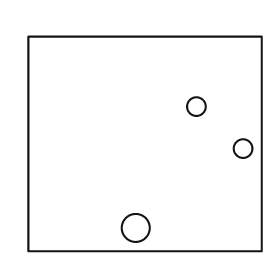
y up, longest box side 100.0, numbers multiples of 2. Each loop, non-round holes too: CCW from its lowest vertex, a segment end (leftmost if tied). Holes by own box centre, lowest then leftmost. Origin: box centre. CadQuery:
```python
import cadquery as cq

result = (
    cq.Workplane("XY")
    .moveTo(-50.0, -46.0)
    .lineTo(50.0, -46.0)
    .lineTo(50.0, 46.0)
    .lineTo(-50.0, 46.0)
    .close()
    .moveTo(-4.0, -36.0)
    .circle(6.0)
    .moveTo(42.0, -2.0)
    .circle(4.0)
    .moveTo(22.0, 16.0)
    .circle(4.0)
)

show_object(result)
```